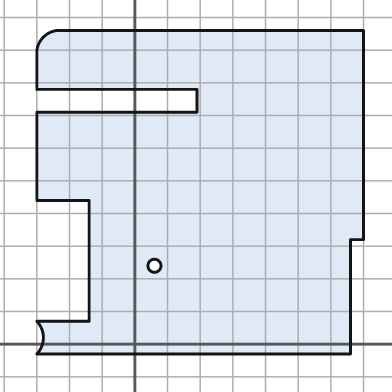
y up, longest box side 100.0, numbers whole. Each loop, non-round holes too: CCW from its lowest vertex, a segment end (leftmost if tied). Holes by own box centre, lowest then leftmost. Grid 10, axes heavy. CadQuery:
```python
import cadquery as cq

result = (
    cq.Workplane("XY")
    .moveTo(-30.0, -3.0)
    .lineTo(66.0, -3.0)
    .lineTo(66.0, 32.0)
    .lineTo(70.0, 32.0)
    .lineTo(70.0, 96.0)
    .lineTo(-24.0, 96.0)
    .threePointArc((-28.0, 94.0), (-30.0, 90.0))
    .lineTo(-30.0, 78.0)
    .lineTo(19.0, 78.0)
    .lineTo(19.0, 71.0)
    .lineTo(-30.0, 71.0)
    .lineTo(-30.0, 44.0)
    .lineTo(-14.0, 44.0)
    .lineTo(-14.0, 7.0)
    .lineTo(-30.0, 7.0)
    .threePointArc((-28.0, 2.0), (-30.0, -3.0))
    .close()
    .moveTo(6.0, 24.0)
    .circle(2.0)
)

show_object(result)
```